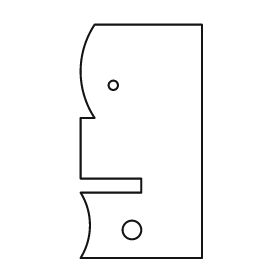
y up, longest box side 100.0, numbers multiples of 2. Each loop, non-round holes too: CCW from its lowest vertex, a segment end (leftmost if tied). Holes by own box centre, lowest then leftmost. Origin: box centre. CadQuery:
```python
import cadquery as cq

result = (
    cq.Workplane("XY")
    .moveTo(-26.0, -50.0)
    .lineTo(26.0, -50.0)
    .lineTo(26.0, 50.0)
    .lineTo(-20.0, 50.0)
    .threePointArc((-26.0, 30.0), (-20.0, 10.0))
    .lineTo(-26.0, 10.0)
    .lineTo(-26.0, -16.0)
    .lineTo(0.0, -16.0)
    .lineTo(0.0, -22.0)
    .lineTo(-26.0, -22.0)
    .threePointArc((-22.0, -36.0), (-26.0, -50.0))
    .close()
    .moveTo(-4.0, -38.0)
    .circle(4.0)
    .moveTo(-12.0, 24.0)
    .circle(2.0)
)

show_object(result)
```